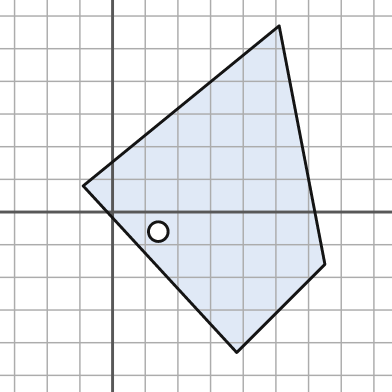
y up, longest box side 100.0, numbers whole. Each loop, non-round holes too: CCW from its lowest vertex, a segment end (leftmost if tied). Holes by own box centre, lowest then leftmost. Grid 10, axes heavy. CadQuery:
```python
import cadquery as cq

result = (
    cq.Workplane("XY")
    .moveTo(38.0, -43.0)
    .lineTo(65.0, -16.0)
    .lineTo(51.0, 57.0)
    .lineTo(-9.0, 8.0)
    .close()
    .moveTo(14.0, -6.0)
    .circle(3.0)
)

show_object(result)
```